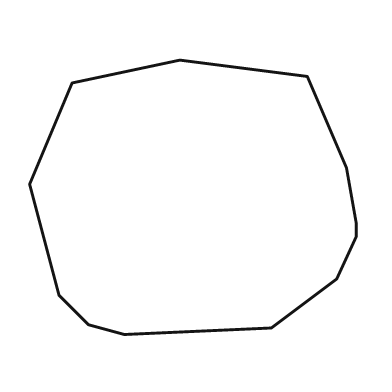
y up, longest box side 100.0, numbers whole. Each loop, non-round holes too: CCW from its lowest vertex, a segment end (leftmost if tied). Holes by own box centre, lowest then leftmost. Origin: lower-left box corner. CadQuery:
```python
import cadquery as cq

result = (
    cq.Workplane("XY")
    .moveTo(29.0, 0.0)
    .lineTo(74.0, 2.0)
    .lineTo(94.0, 17.0)
    .lineTo(100.0, 30.0)
    .lineTo(100.0, 34.0)
    .lineTo(97.0, 51.0)
    .lineTo(85.0, 79.0)
    .lineTo(46.0, 84.0)
    .lineTo(13.0, 77.0)
    .lineTo(0.0, 46.0)
    .lineTo(9.0, 12.0)
    .lineTo(18.0, 3.0)
    .close()
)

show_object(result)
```